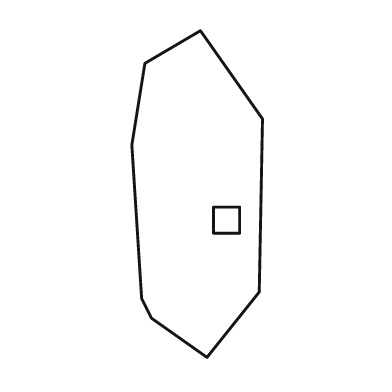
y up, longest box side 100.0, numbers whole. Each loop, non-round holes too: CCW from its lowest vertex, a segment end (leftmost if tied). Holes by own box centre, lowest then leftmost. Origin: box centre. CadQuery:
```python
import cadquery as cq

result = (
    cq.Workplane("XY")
    .moveTo(3.0, -50.0)
    .lineTo(19.0, -30.0)
    .lineTo(20.0, 23.0)
    .lineTo(1.0, 50.0)
    .lineTo(-16.0, 40.0)
    .lineTo(-20.0, 15.0)
    .lineTo(-17.0, -32.0)
    .lineTo(-14.0, -38.0)
    .close()
    .moveTo(5.0, -12.0)
    .lineTo(13.0, -12.0)
    .lineTo(13.0, -4.0)
    .lineTo(5.0, -4.0)
    .close()
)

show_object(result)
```